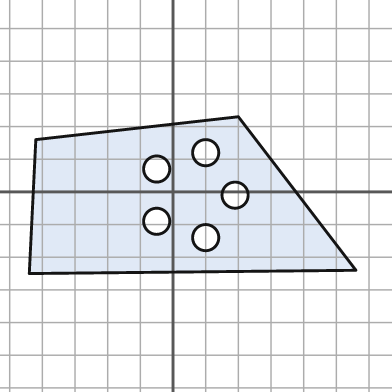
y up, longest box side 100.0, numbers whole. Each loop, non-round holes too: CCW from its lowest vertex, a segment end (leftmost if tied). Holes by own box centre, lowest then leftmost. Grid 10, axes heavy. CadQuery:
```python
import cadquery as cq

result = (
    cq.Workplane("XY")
    .moveTo(-44.0, -25.0)
    .lineTo(56.0, -24.0)
    .lineTo(20.0, 23.0)
    .lineTo(-42.0, 16.0)
    .close()
    .moveTo(10.0, -14.0)
    .circle(4.0)
    .moveTo(-5.0, -9.0)
    .circle(4.0)
    .moveTo(19.0, -1.0)
    .circle(4.0)
    .moveTo(-5.0, 7.0)
    .circle(4.0)
    .moveTo(10.0, 12.0)
    .circle(4.0)
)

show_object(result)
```